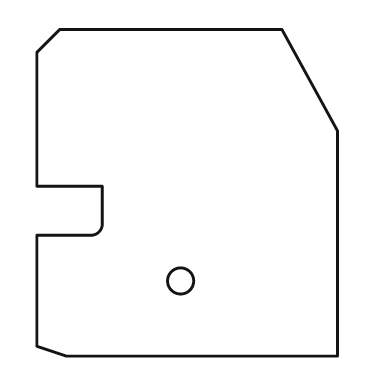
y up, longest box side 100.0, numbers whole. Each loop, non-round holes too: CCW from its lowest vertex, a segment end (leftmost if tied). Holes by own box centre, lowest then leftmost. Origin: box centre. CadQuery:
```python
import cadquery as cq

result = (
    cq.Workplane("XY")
    .moveTo(-37.0, -50.0)
    .lineTo(46.0, -50.0)
    .lineTo(46.0, 19.0)
    .lineTo(29.0, 50.0)
    .lineTo(-39.0, 50.0)
    .lineTo(-46.0, 43.0)
    .lineTo(-46.0, 2.0)
    .lineTo(-26.0, 2.0)
    .lineTo(-26.0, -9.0)
    .threePointArc((-27.0, -12.0), (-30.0, -13.0))
    .lineTo(-46.0, -13.0)
    .lineTo(-46.0, -47.0)
    .close()
    .moveTo(-2.0, -27.0)
    .circle(4.0)
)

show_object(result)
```